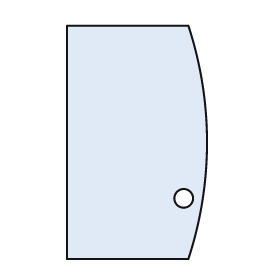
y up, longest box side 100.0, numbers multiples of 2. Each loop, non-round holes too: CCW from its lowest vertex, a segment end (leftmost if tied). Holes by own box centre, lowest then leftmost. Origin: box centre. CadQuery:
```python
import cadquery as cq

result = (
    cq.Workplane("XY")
    .moveTo(-30.0, -50.0)
    .lineTo(22.0, -50.0)
    .threePointArc((30.0, 0.0), (22.0, 50.0))
    .lineTo(-30.0, 50.0)
    .close()
    .moveTo(20.0, -24.0)
    .circle(4.0)
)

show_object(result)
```